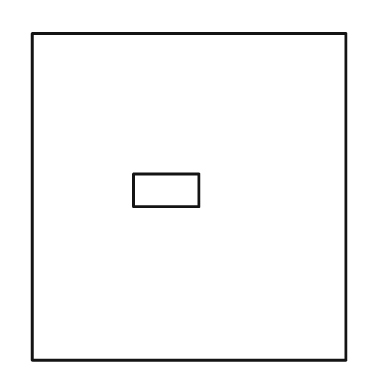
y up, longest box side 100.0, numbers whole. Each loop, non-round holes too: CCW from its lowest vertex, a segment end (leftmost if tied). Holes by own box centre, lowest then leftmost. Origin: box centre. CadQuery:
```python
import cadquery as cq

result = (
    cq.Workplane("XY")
    .moveTo(-48.0, -50.0)
    .lineTo(48.0, -50.0)
    .lineTo(48.0, 50.0)
    .lineTo(-48.0, 50.0)
    .close()
    .moveTo(-17.0, -3.0)
    .lineTo(3.0, -3.0)
    .lineTo(3.0, 7.0)
    .lineTo(-17.0, 7.0)
    .close()
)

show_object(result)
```